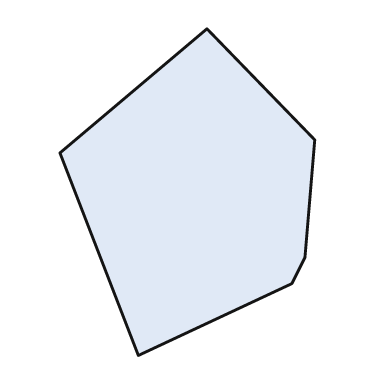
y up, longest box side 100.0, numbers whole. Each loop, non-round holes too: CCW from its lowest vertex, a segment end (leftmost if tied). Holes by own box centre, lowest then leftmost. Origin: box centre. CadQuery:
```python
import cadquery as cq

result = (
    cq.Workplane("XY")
    .moveTo(-15.0, -50.0)
    .lineTo(32.0, -28.0)
    .lineTo(36.0, -20.0)
    .lineTo(39.0, 16.0)
    .lineTo(6.0, 50.0)
    .lineTo(-39.0, 12.0)
    .close()
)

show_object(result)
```